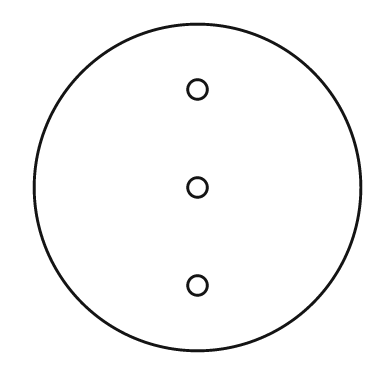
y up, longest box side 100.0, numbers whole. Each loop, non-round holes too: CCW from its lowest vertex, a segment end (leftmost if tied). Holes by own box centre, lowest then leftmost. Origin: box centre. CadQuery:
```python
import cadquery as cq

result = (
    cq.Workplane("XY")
    .moveTo(0.0, 0.0)
    .circle(50.0)
    .moveTo(0.0, -30.0)
    .circle(3.0)
    .moveTo(0.0, 0.0)
    .circle(3.0)
    .moveTo(0.0, 30.0)
    .circle(3.0)
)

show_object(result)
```